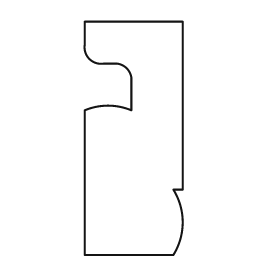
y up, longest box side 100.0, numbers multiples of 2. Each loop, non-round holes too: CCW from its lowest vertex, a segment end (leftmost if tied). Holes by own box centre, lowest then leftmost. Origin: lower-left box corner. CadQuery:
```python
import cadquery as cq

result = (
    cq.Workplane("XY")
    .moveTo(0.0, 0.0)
    .lineTo(38.0, 0.0)
    .threePointArc((42.0, 14.0), (38.0, 28.0))
    .lineTo(42.0, 28.0)
    .lineTo(42.0, 100.0)
    .lineTo(0.0, 100.0)
    .lineTo(0.0, 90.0)
    .threePointArc((2.0, 84.0), (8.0, 82.0))
    .lineTo(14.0, 82.0)
    .threePointArc((18.0, 80.0), (20.0, 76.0))
    .lineTo(20.0, 62.0)
    .threePointArc((10.0, 64.0), (0.0, 62.0))
    .close()
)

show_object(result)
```